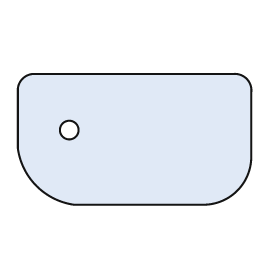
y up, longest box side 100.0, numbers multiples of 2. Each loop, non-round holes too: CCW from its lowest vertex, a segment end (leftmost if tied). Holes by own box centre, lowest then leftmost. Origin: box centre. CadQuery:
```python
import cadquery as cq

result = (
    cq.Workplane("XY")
    .moveTo(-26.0, -28.0)
    .lineTo(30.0, -28.0)
    .threePointArc((44.0, -22.0), (50.0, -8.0))
    .lineTo(50.0, 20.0)
    .threePointArc((48.0, 26.0), (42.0, 28.0))
    .lineTo(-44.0, 28.0)
    .threePointArc((-48.0, 26.0), (-50.0, 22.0))
    .lineTo(-50.0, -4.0)
    .threePointArc((-42.0, -20.0), (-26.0, -28.0))
    .close()
    .moveTo(-28.0, 4.0)
    .circle(4.0)
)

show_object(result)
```